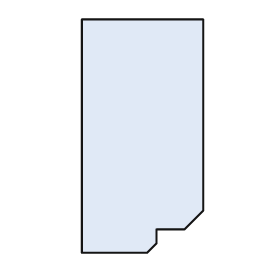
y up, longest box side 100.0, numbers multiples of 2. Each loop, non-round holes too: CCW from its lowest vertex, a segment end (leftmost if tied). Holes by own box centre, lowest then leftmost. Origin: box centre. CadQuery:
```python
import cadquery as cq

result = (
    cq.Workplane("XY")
    .moveTo(-26.0, -50.0)
    .lineTo(2.0, -50.0)
    .lineTo(6.0, -46.0)
    .lineTo(6.0, -40.0)
    .lineTo(18.0, -40.0)
    .lineTo(26.0, -32.0)
    .lineTo(26.0, 50.0)
    .lineTo(-26.0, 50.0)
    .close()
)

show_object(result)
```